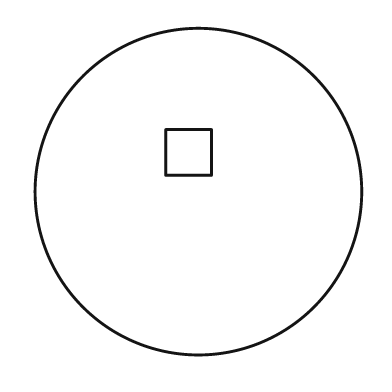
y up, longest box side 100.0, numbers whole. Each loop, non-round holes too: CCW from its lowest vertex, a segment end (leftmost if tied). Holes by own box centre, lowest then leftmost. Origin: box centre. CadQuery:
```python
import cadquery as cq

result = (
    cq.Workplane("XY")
    .moveTo(0.0, 0.0)
    .circle(50.0)
    .moveTo(-10.0, 5.0)
    .lineTo(4.0, 5.0)
    .lineTo(4.0, 19.0)
    .lineTo(-10.0, 19.0)
    .close()
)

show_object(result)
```